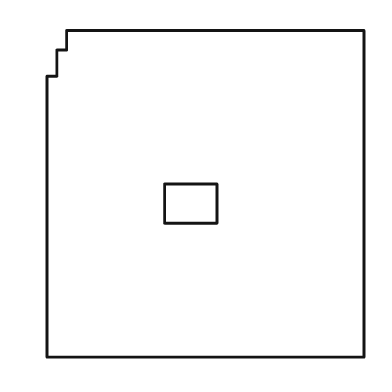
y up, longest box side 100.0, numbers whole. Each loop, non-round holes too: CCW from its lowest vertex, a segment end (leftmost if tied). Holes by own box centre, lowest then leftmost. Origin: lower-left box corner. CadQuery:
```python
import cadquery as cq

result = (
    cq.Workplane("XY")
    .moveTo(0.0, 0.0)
    .lineTo(97.0, 0.0)
    .lineTo(97.0, 100.0)
    .lineTo(6.0, 100.0)
    .lineTo(6.0, 94.0)
    .lineTo(3.0, 94.0)
    .lineTo(3.0, 86.0)
    .lineTo(0.0, 86.0)
    .close()
    .moveTo(36.0, 41.0)
    .lineTo(52.0, 41.0)
    .lineTo(52.0, 53.0)
    .lineTo(36.0, 53.0)
    .close()
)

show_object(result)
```